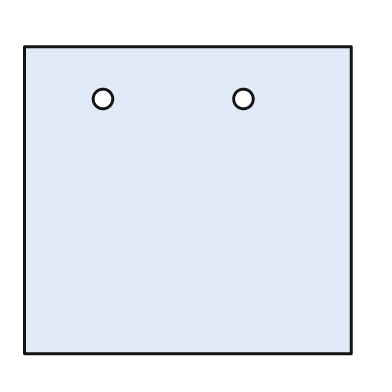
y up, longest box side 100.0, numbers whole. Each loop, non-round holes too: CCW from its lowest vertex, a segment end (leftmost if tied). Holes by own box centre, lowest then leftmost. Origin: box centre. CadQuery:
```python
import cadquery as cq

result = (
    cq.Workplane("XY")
    .moveTo(-50.0, -47.0)
    .lineTo(50.0, -47.0)
    .lineTo(50.0, 47.0)
    .lineTo(-50.0, 47.0)
    .close()
    .moveTo(-26.0, 31.0)
    .circle(3.0)
    .moveTo(17.0, 31.0)
    .circle(3.0)
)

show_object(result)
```